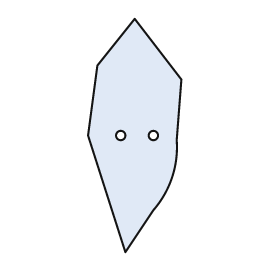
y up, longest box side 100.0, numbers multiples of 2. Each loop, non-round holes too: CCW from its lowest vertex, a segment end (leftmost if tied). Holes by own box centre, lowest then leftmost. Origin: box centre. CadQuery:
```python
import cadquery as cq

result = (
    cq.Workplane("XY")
    .moveTo(-4.0, -50.0)
    .lineTo(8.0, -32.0)
    .threePointArc((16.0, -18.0), (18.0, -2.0))
    .lineTo(20.0, 24.0)
    .lineTo(0.0, 50.0)
    .lineTo(-16.0, 30.0)
    .lineTo(-20.0, 0.0)
    .close()
    .moveTo(-6.0, 0.0)
    .circle(2.0)
    .moveTo(8.0, 0.0)
    .circle(2.0)
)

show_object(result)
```